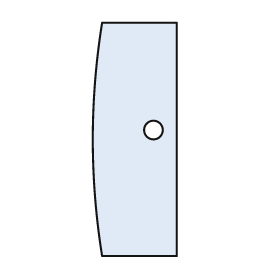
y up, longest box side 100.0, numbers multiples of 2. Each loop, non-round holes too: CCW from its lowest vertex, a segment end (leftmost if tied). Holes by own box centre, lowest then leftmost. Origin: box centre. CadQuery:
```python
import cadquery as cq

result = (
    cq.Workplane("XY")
    .moveTo(-14.0, -50.0)
    .lineTo(18.0, -50.0)
    .lineTo(18.0, 50.0)
    .lineTo(-14.0, 50.0)
    .threePointArc((-18.0, 0.0), (-14.0, -50.0))
    .close()
    .moveTo(8.0, 4.0)
    .circle(4.0)
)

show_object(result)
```